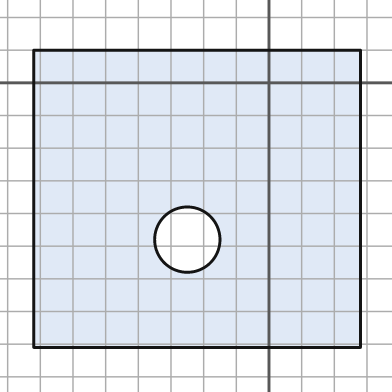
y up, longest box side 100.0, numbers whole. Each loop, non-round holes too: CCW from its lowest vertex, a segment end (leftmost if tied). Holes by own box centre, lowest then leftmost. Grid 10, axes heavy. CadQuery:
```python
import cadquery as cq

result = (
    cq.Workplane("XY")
    .moveTo(-72.0, -81.0)
    .lineTo(28.0, -81.0)
    .lineTo(28.0, 10.0)
    .lineTo(-72.0, 10.0)
    .close()
    .moveTo(-25.0, -48.0)
    .circle(10.0)
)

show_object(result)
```